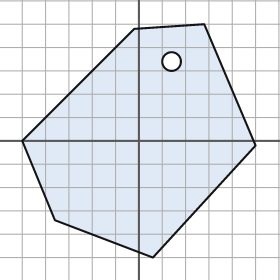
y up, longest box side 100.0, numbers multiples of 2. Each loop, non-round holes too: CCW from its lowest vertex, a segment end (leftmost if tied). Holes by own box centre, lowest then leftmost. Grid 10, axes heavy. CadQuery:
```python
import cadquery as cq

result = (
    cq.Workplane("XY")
    .moveTo(6.0, -50.0)
    .lineTo(50.0, -2.0)
    .lineTo(28.0, 50.0)
    .lineTo(-2.0, 48.0)
    .lineTo(-50.0, 0.0)
    .lineTo(-36.0, -34.0)
    .close()
    .moveTo(14.0, 34.0)
    .circle(4.0)
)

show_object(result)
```